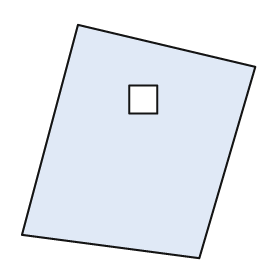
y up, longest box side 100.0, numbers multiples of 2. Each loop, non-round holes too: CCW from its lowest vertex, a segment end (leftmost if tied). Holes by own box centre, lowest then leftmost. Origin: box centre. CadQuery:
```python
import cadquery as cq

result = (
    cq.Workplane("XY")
    .moveTo(26.0, -50.0)
    .lineTo(50.0, 32.0)
    .lineTo(-26.0, 50.0)
    .lineTo(-50.0, -40.0)
    .close()
    .moveTo(-4.0, 12.0)
    .lineTo(8.0, 12.0)
    .lineTo(8.0, 24.0)
    .lineTo(-4.0, 24.0)
    .close()
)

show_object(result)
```